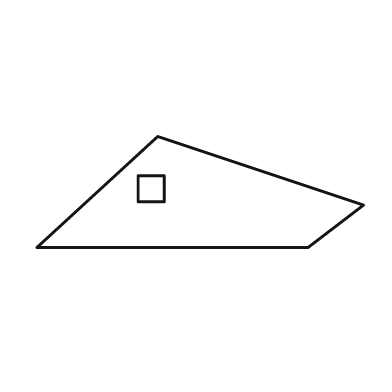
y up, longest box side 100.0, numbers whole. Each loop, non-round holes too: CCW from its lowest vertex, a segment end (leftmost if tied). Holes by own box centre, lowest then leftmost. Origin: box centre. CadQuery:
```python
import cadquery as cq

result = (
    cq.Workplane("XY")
    .moveTo(-50.0, -17.0)
    .lineTo(33.0, -17.0)
    .lineTo(50.0, -4.0)
    .lineTo(-13.0, 17.0)
    .close()
    .moveTo(-19.0, -3.0)
    .lineTo(-11.0, -3.0)
    .lineTo(-11.0, 5.0)
    .lineTo(-19.0, 5.0)
    .close()
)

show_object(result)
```